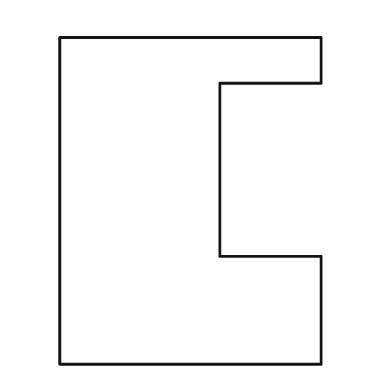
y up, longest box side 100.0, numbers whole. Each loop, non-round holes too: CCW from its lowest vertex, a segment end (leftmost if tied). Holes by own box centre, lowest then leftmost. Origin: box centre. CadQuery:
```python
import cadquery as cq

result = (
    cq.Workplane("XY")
    .moveTo(-40.0, -50.0)
    .lineTo(40.0, -50.0)
    .lineTo(40.0, -17.0)
    .lineTo(9.0, -17.0)
    .lineTo(9.0, 36.0)
    .lineTo(40.0, 36.0)
    .lineTo(40.0, 50.0)
    .lineTo(-40.0, 50.0)
    .close()
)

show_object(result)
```